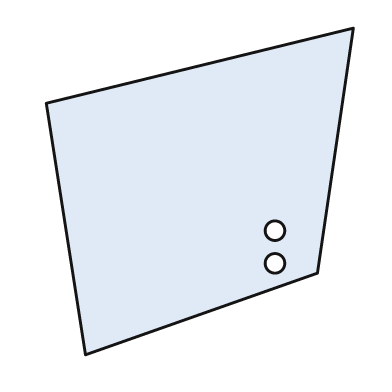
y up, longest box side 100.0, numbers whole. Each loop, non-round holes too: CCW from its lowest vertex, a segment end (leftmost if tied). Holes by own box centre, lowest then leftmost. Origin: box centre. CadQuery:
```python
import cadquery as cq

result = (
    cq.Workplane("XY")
    .moveTo(-35.0, -50.0)
    .lineTo(36.0, -25.0)
    .lineTo(47.0, 50.0)
    .lineTo(-47.0, 27.0)
    .close()
    .moveTo(23.0, -22.0)
    .circle(3.0)
    .moveTo(23.0, -12.0)
    .circle(3.0)
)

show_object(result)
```